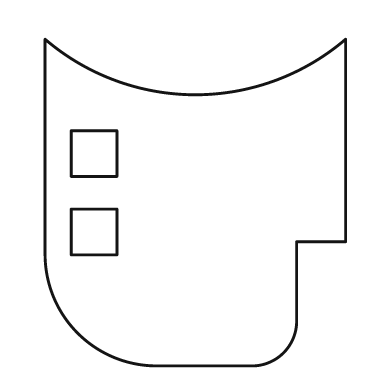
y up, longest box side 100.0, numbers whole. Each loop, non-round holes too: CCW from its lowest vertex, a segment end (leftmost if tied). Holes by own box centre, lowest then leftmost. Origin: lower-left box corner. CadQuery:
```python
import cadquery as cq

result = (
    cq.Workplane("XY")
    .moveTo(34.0, 0.0)
    .lineTo(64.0, 0.0)
    .threePointArc((73.0, 4.0), (77.0, 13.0))
    .lineTo(77.0, 38.0)
    .lineTo(92.0, 38.0)
    .lineTo(92.0, 100.0)
    .threePointArc((46.0, 83.0), (0.0, 100.0))
    .lineTo(0.0, 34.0)
    .threePointArc((10.0, 10.0), (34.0, 0.0))
    .close()
    .moveTo(8.0, 34.0)
    .lineTo(22.0, 34.0)
    .lineTo(22.0, 48.0)
    .lineTo(8.0, 48.0)
    .close()
    .moveTo(8.0, 58.0)
    .lineTo(22.0, 58.0)
    .lineTo(22.0, 72.0)
    .lineTo(8.0, 72.0)
    .close()
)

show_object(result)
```